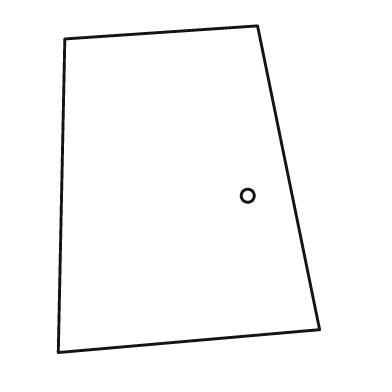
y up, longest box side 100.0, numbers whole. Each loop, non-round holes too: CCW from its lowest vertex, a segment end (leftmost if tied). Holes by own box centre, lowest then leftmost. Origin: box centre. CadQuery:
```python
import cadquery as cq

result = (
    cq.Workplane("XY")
    .moveTo(-40.0, -50.0)
    .lineTo(40.0, -43.0)
    .lineTo(21.0, 50.0)
    .lineTo(-38.0, 46.0)
    .close()
    .moveTo(18.0, -2.0)
    .circle(2.0)
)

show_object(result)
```